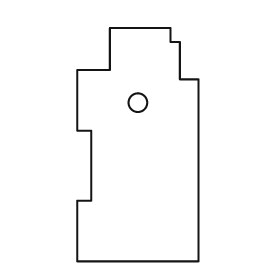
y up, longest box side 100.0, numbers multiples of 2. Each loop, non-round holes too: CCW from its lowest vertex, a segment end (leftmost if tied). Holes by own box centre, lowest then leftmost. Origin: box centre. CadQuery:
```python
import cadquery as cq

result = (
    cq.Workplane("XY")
    .moveTo(-26.0, -50.0)
    .lineTo(26.0, -50.0)
    .lineTo(26.0, 28.0)
    .lineTo(18.0, 28.0)
    .lineTo(18.0, 44.0)
    .lineTo(14.0, 44.0)
    .lineTo(14.0, 50.0)
    .lineTo(-12.0, 50.0)
    .lineTo(-12.0, 32.0)
    .lineTo(-26.0, 32.0)
    .lineTo(-26.0, 6.0)
    .lineTo(-20.0, 6.0)
    .lineTo(-20.0, -24.0)
    .lineTo(-26.0, -24.0)
    .close()
    .moveTo(0.0, 18.0)
    .circle(4.0)
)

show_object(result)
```